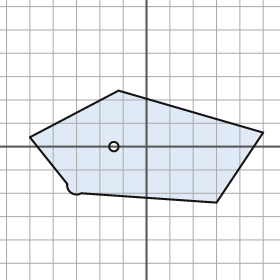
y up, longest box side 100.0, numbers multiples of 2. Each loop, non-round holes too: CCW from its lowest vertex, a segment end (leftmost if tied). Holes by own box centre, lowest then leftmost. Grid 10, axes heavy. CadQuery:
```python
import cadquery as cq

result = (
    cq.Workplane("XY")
    .moveTo(30.0, -24.0)
    .lineTo(50.0, 6.0)
    .lineTo(-12.0, 24.0)
    .lineTo(-50.0, 4.0)
    .lineTo(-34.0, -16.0)
    .threePointArc((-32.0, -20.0), (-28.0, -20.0))
    .close()
    .moveTo(-14.0, 0.0)
    .circle(2.0)
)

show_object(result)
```